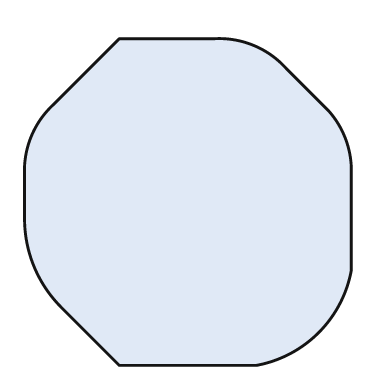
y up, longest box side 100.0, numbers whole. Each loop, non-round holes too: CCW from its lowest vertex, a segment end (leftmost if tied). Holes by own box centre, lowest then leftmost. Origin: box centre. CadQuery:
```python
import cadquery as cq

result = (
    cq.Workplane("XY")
    .moveTo(-21.0, -50.0)
    .lineTo(21.0, -50.0)
    .threePointArc((40.0, -40.0), (50.0, -21.0))
    .lineTo(50.0, 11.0)
    .threePointArc((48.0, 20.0), (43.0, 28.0))
    .lineTo(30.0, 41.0)
    .threePointArc((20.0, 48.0), (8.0, 50.0))
    .lineTo(-21.0, 50.0)
    .lineTo(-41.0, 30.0)
    .threePointArc((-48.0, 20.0), (-50.0, 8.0))
    .lineTo(-50.0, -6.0)
    .threePointArc((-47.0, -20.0), (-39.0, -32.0))
    .close()
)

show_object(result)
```